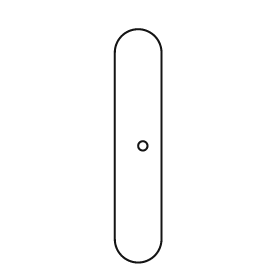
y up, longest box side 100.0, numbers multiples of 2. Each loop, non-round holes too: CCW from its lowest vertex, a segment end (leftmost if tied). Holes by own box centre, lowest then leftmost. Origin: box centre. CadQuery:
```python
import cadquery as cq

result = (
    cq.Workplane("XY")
    .moveTo(-10.0, -40.0)
    .threePointArc((0.0, -50.0), (10.0, -40.0))
    .lineTo(10.0, 40.0)
    .threePointArc((0.0, 50.0), (-10.0, 40.0))
    .close()
    .moveTo(2.0, 0.0)
    .circle(2.0)
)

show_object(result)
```